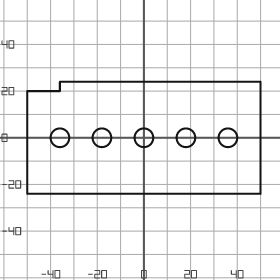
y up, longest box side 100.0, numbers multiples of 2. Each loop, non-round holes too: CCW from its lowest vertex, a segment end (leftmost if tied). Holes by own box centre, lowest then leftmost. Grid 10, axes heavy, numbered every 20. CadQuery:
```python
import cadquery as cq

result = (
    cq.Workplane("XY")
    .moveTo(-50.0, -24.0)
    .lineTo(50.0, -24.0)
    .lineTo(50.0, 24.0)
    .lineTo(-36.0, 24.0)
    .lineTo(-36.0, 20.0)
    .lineTo(-50.0, 20.0)
    .close()
    .moveTo(-36.0, 0.0)
    .circle(4.0)
    .moveTo(-18.0, 0.0)
    .circle(4.0)
    .moveTo(0.0, 0.0)
    .circle(4.0)
    .moveTo(18.0, 0.0)
    .circle(4.0)
    .moveTo(36.0, 0.0)
    .circle(4.0)
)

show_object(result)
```